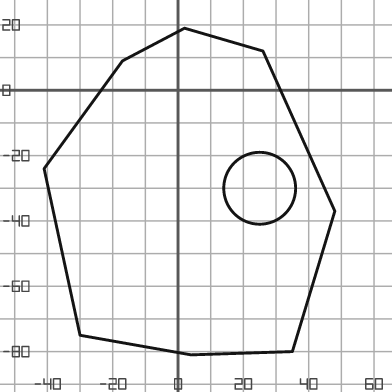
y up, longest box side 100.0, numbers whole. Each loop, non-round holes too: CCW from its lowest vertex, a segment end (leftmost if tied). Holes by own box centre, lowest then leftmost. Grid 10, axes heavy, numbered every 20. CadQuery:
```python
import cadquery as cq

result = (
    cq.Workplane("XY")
    .moveTo(4.0, -81.0)
    .lineTo(35.0, -80.0)
    .lineTo(48.0, -37.0)
    .lineTo(26.0, 12.0)
    .lineTo(2.0, 19.0)
    .lineTo(-17.0, 9.0)
    .lineTo(-41.0, -24.0)
    .lineTo(-30.0, -75.0)
    .close()
    .moveTo(25.0, -30.0)
    .circle(11.0)
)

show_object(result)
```